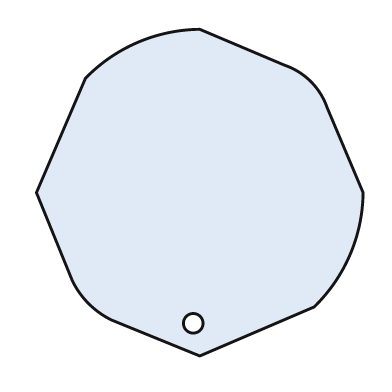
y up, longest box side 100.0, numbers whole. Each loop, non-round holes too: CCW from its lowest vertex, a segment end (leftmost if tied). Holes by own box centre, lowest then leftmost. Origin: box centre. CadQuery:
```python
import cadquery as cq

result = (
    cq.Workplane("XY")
    .moveTo(0.0, -50.0)
    .lineTo(35.0, -35.0)
    .threePointArc((46.0, -19.0), (50.0, 0.0))
    .lineTo(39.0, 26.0)
    .threePointArc((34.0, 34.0), (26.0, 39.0))
    .lineTo(0.0, 50.0)
    .threePointArc((-19.0, 46.0), (-35.0, 35.0))
    .lineTo(-50.0, 0.0)
    .lineTo(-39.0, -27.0)
    .threePointArc((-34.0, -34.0), (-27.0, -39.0))
    .close()
    .moveTo(-2.0, -40.0)
    .circle(3.0)
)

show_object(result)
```